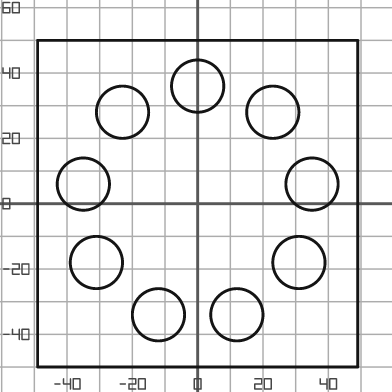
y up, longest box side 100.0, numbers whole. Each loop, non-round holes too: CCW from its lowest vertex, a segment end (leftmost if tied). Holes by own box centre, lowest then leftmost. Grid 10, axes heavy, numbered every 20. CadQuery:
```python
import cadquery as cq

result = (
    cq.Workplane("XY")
    .moveTo(-49.0, -50.0)
    .lineTo(49.0, -50.0)
    .lineTo(49.0, 50.0)
    .lineTo(-49.0, 50.0)
    .close()
    .moveTo(-12.0, -34.0)
    .circle(8.0)
    .moveTo(12.0, -34.0)
    .circle(8.0)
    .moveTo(-31.0, -18.0)
    .circle(8.0)
    .moveTo(31.0, -18.0)
    .circle(8.0)
    .moveTo(-35.0, 6.0)
    .circle(8.0)
    .moveTo(35.0, 6.0)
    .circle(8.0)
    .moveTo(-23.0, 28.0)
    .circle(8.0)
    .moveTo(23.0, 28.0)
    .circle(8.0)
    .moveTo(0.0, 36.0)
    .circle(8.0)
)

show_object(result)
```